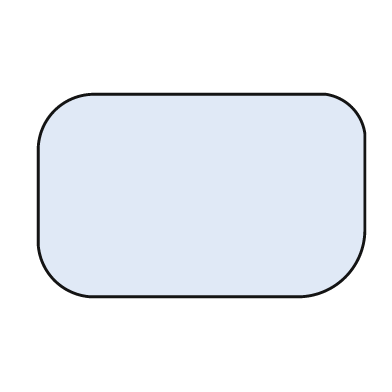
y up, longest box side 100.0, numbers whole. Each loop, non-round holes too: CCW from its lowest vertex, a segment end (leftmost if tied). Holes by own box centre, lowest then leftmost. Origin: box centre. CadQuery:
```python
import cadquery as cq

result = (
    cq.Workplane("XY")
    .moveTo(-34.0, -31.0)
    .lineTo(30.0, -31.0)
    .threePointArc((44.0, -25.0), (50.0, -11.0))
    .lineTo(50.0, 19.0)
    .threePointArc((46.0, 27.0), (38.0, 31.0))
    .lineTo(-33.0, 31.0)
    .threePointArc((-45.0, 26.0), (-50.0, 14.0))
    .lineTo(-50.0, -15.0)
    .threePointArc((-45.0, -26.0), (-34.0, -31.0))
    .close()
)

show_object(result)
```